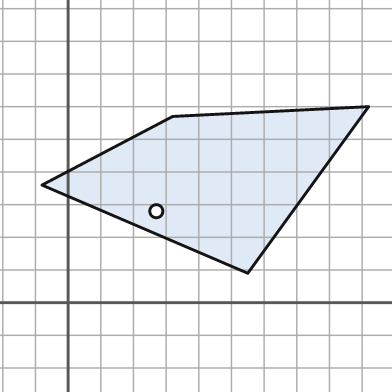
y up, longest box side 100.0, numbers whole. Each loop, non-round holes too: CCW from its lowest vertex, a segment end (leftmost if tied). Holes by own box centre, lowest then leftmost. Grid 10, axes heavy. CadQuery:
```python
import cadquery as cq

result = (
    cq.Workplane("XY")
    .moveTo(55.0, 9.0)
    .lineTo(92.0, 60.0)
    .lineTo(32.0, 57.0)
    .lineTo(-8.0, 36.0)
    .close()
    .moveTo(27.0, 28.0)
    .circle(2.0)
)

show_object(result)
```